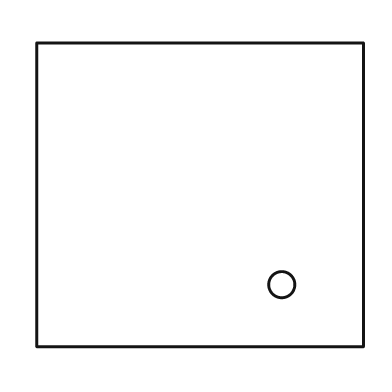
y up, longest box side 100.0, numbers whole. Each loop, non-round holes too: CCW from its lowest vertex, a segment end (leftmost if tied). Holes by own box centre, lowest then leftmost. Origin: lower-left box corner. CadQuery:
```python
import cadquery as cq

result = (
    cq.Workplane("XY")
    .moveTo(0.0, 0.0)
    .lineTo(100.0, 0.0)
    .lineTo(100.0, 93.0)
    .lineTo(0.0, 93.0)
    .close()
    .moveTo(75.0, 19.0)
    .circle(4.0)
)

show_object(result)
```